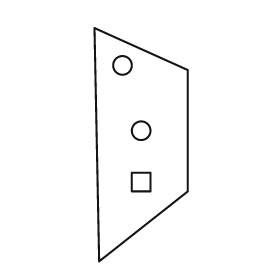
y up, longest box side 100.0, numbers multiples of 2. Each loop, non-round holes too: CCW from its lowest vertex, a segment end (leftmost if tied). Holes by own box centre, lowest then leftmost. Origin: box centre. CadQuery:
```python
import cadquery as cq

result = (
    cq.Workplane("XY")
    .moveTo(-18.0, -50.0)
    .lineTo(20.0, -20.0)
    .lineTo(20.0, 32.0)
    .lineTo(-20.0, 50.0)
    .close()
    .moveTo(-4.0, -20.0)
    .lineTo(4.0, -20.0)
    .lineTo(4.0, -12.0)
    .lineTo(-4.0, -12.0)
    .close()
    .moveTo(0.0, 6.0)
    .circle(4.0)
    .moveTo(-8.0, 34.0)
    .circle(4.0)
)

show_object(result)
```